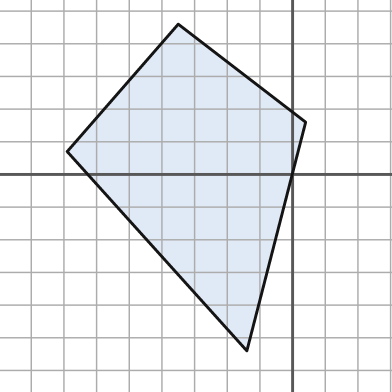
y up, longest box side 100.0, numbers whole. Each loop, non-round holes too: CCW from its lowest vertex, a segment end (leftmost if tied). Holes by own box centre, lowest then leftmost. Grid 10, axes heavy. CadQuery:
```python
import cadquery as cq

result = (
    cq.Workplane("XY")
    .moveTo(-14.0, -54.0)
    .lineTo(4.0, 16.0)
    .lineTo(-35.0, 46.0)
    .lineTo(-69.0, 7.0)
    .close()
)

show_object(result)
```